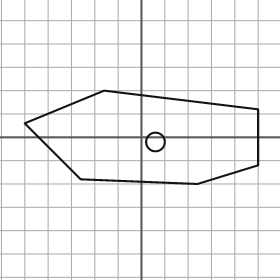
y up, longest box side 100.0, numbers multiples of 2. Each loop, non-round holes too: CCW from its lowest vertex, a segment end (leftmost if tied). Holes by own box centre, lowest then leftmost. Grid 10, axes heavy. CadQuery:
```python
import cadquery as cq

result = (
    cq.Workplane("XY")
    .moveTo(24.0, -20.0)
    .lineTo(50.0, -12.0)
    .lineTo(50.0, 12.0)
    .lineTo(-16.0, 20.0)
    .lineTo(-50.0, 6.0)
    .lineTo(-26.0, -18.0)
    .close()
    .moveTo(6.0, -2.0)
    .circle(4.0)
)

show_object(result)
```